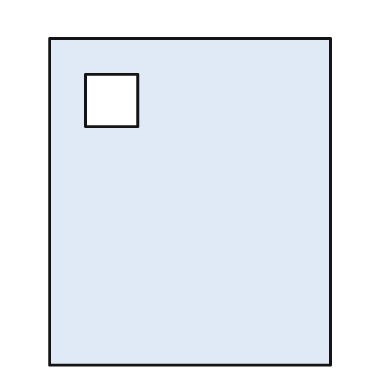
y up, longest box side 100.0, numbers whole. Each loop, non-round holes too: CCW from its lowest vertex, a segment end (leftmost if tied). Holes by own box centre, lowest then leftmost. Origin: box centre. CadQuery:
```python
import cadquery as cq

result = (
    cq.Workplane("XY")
    .moveTo(-43.0, -50.0)
    .lineTo(43.0, -50.0)
    .lineTo(43.0, 50.0)
    .lineTo(-43.0, 50.0)
    .close()
    .moveTo(-32.0, 23.0)
    .lineTo(-16.0, 23.0)
    .lineTo(-16.0, 39.0)
    .lineTo(-32.0, 39.0)
    .close()
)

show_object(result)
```